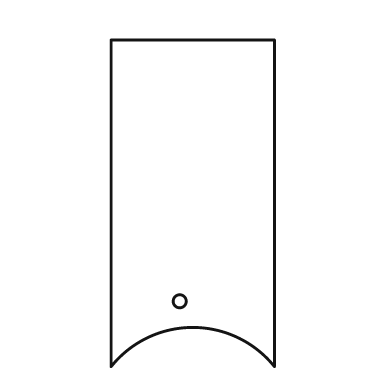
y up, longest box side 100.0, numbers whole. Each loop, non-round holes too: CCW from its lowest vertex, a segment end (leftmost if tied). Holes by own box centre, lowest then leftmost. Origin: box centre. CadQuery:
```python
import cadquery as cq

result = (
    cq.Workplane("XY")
    .moveTo(-25.0, -50.0)
    .threePointArc((0.0, -38.0), (25.0, -50.0))
    .lineTo(25.0, 50.0)
    .lineTo(-25.0, 50.0)
    .close()
    .moveTo(-4.0, -30.0)
    .circle(2.0)
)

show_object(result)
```